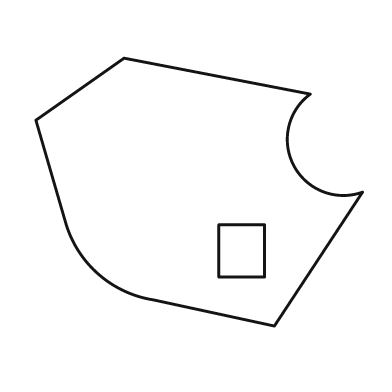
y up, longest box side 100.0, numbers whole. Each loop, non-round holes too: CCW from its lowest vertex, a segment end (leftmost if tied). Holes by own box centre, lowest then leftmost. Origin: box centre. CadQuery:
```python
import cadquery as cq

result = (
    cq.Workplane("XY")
    .moveTo(23.0, -41.0)
    .lineTo(50.0, 0.0)
    .threePointArc((29.0, 8.0), (34.0, 30.0))
    .lineTo(-23.0, 41.0)
    .lineTo(-50.0, 22.0)
    .lineTo(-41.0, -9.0)
    .threePointArc((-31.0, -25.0), (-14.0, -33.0))
    .close()
    .moveTo(6.0, -26.0)
    .lineTo(20.0, -26.0)
    .lineTo(20.0, -10.0)
    .lineTo(6.0, -10.0)
    .close()
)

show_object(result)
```